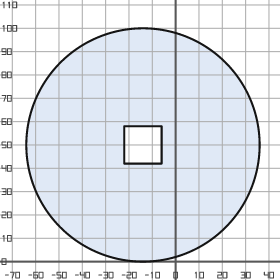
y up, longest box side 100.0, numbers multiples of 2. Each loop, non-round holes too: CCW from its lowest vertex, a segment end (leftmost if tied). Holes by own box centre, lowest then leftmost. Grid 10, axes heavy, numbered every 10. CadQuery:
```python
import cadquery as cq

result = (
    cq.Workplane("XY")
    .moveTo(-14.0, 50.0)
    .circle(50.0)
    .moveTo(-22.0, 42.0)
    .lineTo(-6.0, 42.0)
    .lineTo(-6.0, 58.0)
    .lineTo(-22.0, 58.0)
    .close()
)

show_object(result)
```